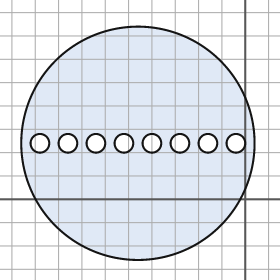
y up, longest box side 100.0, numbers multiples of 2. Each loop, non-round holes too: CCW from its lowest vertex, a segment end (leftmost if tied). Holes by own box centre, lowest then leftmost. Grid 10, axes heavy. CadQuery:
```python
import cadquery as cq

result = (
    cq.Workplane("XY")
    .moveTo(-46.0, 24.0)
    .circle(50.0)
    .moveTo(-88.0, 24.0)
    .circle(4.0)
    .moveTo(-76.0, 24.0)
    .circle(4.0)
    .moveTo(-64.0, 24.0)
    .circle(4.0)
    .moveTo(-52.0, 24.0)
    .circle(4.0)
    .moveTo(-40.0, 24.0)
    .circle(4.0)
    .moveTo(-28.0, 24.0)
    .circle(4.0)
    .moveTo(-16.0, 24.0)
    .circle(4.0)
    .moveTo(-4.0, 24.0)
    .circle(4.0)
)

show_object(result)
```